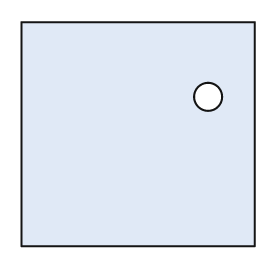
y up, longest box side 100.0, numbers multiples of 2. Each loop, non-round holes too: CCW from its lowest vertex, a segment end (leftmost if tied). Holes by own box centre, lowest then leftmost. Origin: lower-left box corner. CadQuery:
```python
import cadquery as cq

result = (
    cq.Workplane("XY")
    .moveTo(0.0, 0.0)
    .lineTo(100.0, 0.0)
    .lineTo(100.0, 96.0)
    .lineTo(0.0, 96.0)
    .close()
    .moveTo(80.0, 64.0)
    .circle(6.0)
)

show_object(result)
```